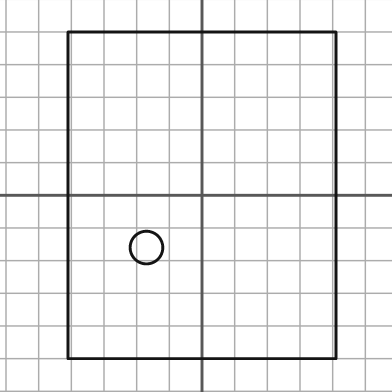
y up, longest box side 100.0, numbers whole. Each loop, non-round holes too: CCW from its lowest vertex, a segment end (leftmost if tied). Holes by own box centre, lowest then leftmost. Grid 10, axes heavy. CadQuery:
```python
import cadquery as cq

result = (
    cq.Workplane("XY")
    .moveTo(-41.0, -50.0)
    .lineTo(41.0, -50.0)
    .lineTo(41.0, 50.0)
    .lineTo(-41.0, 50.0)
    .close()
    .moveTo(-17.0, -16.0)
    .circle(5.0)
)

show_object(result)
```